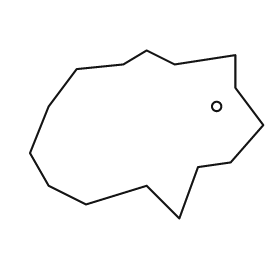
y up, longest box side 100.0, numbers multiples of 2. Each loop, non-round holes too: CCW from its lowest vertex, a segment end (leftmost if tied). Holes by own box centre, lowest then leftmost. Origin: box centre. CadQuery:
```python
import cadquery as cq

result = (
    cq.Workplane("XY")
    .moveTo(14.0, -36.0)
    .lineTo(22.0, -14.0)
    .lineTo(36.0, -12.0)
    .lineTo(50.0, 4.0)
    .lineTo(38.0, 20.0)
    .lineTo(38.0, 34.0)
    .lineTo(12.0, 30.0)
    .lineTo(0.0, 36.0)
    .lineTo(-10.0, 30.0)
    .lineTo(-30.0, 28.0)
    .lineTo(-42.0, 12.0)
    .lineTo(-50.0, -8.0)
    .lineTo(-42.0, -22.0)
    .lineTo(-26.0, -30.0)
    .lineTo(0.0, -22.0)
    .close()
    .moveTo(30.0, 12.0)
    .circle(2.0)
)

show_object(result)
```